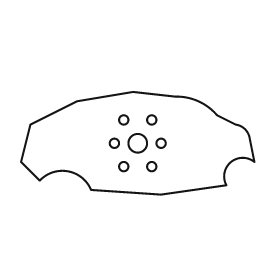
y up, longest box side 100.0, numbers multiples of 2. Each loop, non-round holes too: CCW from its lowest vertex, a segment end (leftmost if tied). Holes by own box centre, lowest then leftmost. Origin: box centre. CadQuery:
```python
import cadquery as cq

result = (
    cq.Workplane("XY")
    .moveTo(10.0, -22.0)
    .lineTo(38.0, -18.0)
    .threePointArc((40.0, -8.0), (50.0, -8.0))
    .lineTo(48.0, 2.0)
    .threePointArc((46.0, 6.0), (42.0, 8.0))
    .lineTo(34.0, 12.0)
    .threePointArc((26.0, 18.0), (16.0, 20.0))
    .lineTo(-2.0, 22.0)
    .lineTo(-26.0, 18.0)
    .lineTo(-46.0, 8.0)
    .lineTo(-50.0, -8.0)
    .lineTo(-42.0, -16.0)
    .threePointArc((-30.0, -12.0), (-20.0, -20.0))
    .close()
    .moveTo(-6.0, -10.0)
    .circle(2.0)
    .moveTo(6.0, -10.0)
    .circle(2.0)
    .moveTo(-10.0, 0.0)
    .circle(2.0)
    .moveTo(0.0, 0.0)
    .circle(4.0)
    .moveTo(10.0, 0.0)
    .circle(2.0)
    .moveTo(-6.0, 10.0)
    .circle(2.0)
    .moveTo(6.0, 10.0)
    .circle(2.0)
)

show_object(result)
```